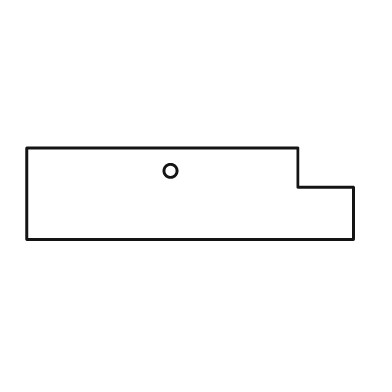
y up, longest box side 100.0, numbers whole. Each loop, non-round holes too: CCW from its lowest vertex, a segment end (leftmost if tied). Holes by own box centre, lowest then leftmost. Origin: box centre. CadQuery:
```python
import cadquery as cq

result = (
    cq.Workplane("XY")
    .moveTo(-50.0, -14.0)
    .lineTo(50.0, -14.0)
    .lineTo(50.0, 2.0)
    .lineTo(33.0, 2.0)
    .lineTo(33.0, 14.0)
    .lineTo(-50.0, 14.0)
    .close()
    .moveTo(-6.0, 7.0)
    .circle(2.0)
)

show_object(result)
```